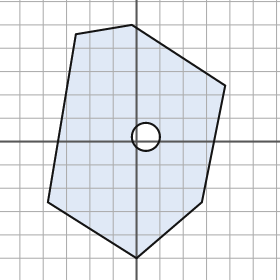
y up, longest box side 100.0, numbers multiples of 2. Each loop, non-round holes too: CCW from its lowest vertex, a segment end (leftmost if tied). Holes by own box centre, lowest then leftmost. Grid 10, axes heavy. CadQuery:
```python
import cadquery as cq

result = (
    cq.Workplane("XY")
    .moveTo(0.0, -50.0)
    .lineTo(28.0, -26.0)
    .lineTo(38.0, 24.0)
    .lineTo(-2.0, 50.0)
    .lineTo(-26.0, 46.0)
    .lineTo(-38.0, -26.0)
    .close()
    .moveTo(4.0, 2.0)
    .circle(6.0)
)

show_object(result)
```